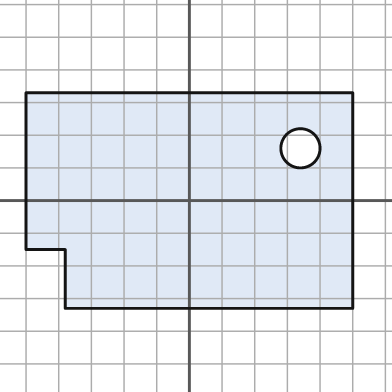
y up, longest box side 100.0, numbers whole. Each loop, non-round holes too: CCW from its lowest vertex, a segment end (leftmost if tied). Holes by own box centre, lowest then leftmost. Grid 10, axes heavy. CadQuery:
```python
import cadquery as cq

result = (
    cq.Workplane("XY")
    .moveTo(-38.0, -33.0)
    .lineTo(50.0, -33.0)
    .lineTo(50.0, 33.0)
    .lineTo(-50.0, 33.0)
    .lineTo(-50.0, -15.0)
    .lineTo(-38.0, -15.0)
    .close()
    .moveTo(34.0, 16.0)
    .circle(6.0)
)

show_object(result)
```